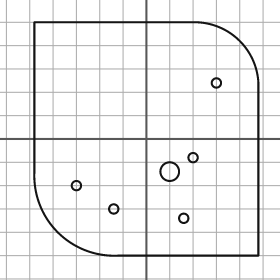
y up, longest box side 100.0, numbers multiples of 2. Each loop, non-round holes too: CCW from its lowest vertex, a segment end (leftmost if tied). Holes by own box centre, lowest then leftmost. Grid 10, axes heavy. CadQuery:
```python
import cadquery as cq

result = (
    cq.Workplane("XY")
    .moveTo(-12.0, -50.0)
    .lineTo(48.0, -50.0)
    .lineTo(48.0, 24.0)
    .threePointArc((40.0, 42.0), (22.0, 50.0))
    .lineTo(-48.0, 50.0)
    .lineTo(-48.0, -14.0)
    .threePointArc((-38.0, -40.0), (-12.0, -50.0))
    .close()
    .moveTo(16.0, -34.0)
    .circle(2.0)
    .moveTo(-14.0, -30.0)
    .circle(2.0)
    .moveTo(-30.0, -20.0)
    .circle(2.0)
    .moveTo(10.0, -14.0)
    .circle(4.0)
    .moveTo(20.0, -8.0)
    .circle(2.0)
    .moveTo(30.0, 24.0)
    .circle(2.0)
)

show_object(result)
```